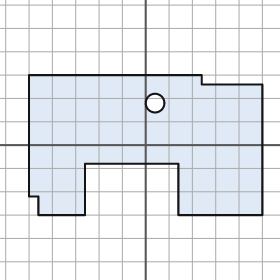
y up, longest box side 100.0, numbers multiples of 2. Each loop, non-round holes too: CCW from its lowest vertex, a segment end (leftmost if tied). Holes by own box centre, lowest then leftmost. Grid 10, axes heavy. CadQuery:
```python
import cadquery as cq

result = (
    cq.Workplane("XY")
    .moveTo(-46.0, -30.0)
    .lineTo(-26.0, -30.0)
    .lineTo(-26.0, -8.0)
    .lineTo(14.0, -8.0)
    .lineTo(14.0, -30.0)
    .lineTo(50.0, -30.0)
    .lineTo(50.0, 26.0)
    .lineTo(24.0, 26.0)
    .lineTo(24.0, 30.0)
    .lineTo(-50.0, 30.0)
    .lineTo(-50.0, -22.0)
    .lineTo(-46.0, -22.0)
    .close()
    .moveTo(4.0, 18.0)
    .circle(4.0)
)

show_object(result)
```